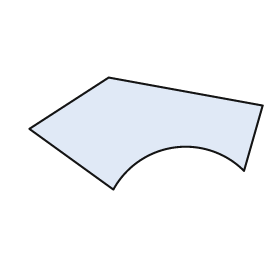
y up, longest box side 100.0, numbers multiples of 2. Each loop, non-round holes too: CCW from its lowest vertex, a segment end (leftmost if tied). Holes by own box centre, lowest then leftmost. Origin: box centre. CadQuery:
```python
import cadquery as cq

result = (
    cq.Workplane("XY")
    .moveTo(-14.0, -24.0)
    .threePointArc((12.0, -6.0), (42.0, -16.0))
    .lineTo(50.0, 12.0)
    .lineTo(-16.0, 24.0)
    .lineTo(-50.0, 2.0)
    .close()
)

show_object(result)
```